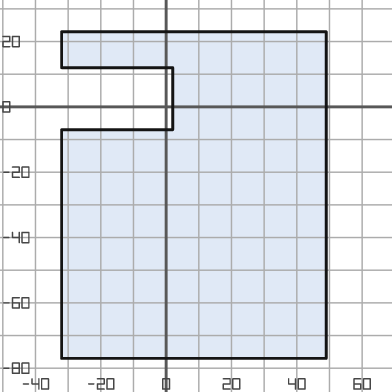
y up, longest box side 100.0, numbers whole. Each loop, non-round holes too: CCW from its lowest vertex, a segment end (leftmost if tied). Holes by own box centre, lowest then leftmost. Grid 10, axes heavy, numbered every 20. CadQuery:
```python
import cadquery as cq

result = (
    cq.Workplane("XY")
    .moveTo(-32.0, -77.0)
    .lineTo(49.0, -77.0)
    .lineTo(49.0, 23.0)
    .lineTo(-32.0, 23.0)
    .lineTo(-32.0, 12.0)
    .lineTo(2.0, 12.0)
    .lineTo(2.0, -7.0)
    .lineTo(-32.0, -7.0)
    .close()
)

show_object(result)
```